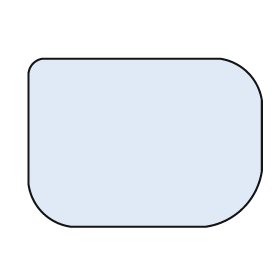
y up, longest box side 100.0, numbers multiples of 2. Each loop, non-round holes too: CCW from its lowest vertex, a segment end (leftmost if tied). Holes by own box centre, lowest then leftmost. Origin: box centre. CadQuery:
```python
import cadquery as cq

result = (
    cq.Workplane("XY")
    .moveTo(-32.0, -36.0)
    .lineTo(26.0, -36.0)
    .threePointArc((42.0, -28.0), (50.0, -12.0))
    .lineTo(50.0, 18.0)
    .threePointArc((44.0, 30.0), (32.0, 36.0))
    .lineTo(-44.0, 36.0)
    .threePointArc((-48.0, 34.0), (-50.0, 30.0))
    .lineTo(-50.0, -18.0)
    .threePointArc((-44.0, -30.0), (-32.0, -36.0))
    .close()
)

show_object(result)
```